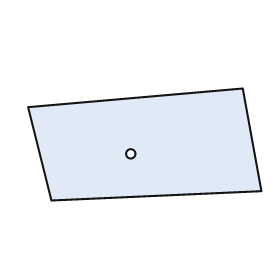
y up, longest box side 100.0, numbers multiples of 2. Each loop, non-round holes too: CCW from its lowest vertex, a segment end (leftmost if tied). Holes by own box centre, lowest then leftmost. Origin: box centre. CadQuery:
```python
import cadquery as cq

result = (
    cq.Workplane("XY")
    .moveTo(-40.0, -24.0)
    .lineTo(50.0, -20.0)
    .lineTo(42.0, 24.0)
    .lineTo(-50.0, 16.0)
    .close()
    .moveTo(-6.0, -4.0)
    .circle(2.0)
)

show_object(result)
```